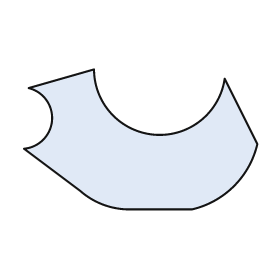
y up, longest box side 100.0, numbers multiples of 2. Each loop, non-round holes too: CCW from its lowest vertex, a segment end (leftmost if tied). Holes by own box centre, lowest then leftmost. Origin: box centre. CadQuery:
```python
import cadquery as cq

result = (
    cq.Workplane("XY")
    .moveTo(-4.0, -30.0)
    .lineTo(22.0, -30.0)
    .threePointArc((40.0, -20.0), (50.0, -2.0))
    .lineTo(36.0, 26.0)
    .threePointArc((6.0, 2.0), (-20.0, 30.0))
    .lineTo(-48.0, 22.0)
    .threePointArc((-38.0, 8.0), (-50.0, -4.0))
    .lineTo(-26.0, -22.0)
    .threePointArc((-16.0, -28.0), (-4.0, -30.0))
    .close()
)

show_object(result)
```